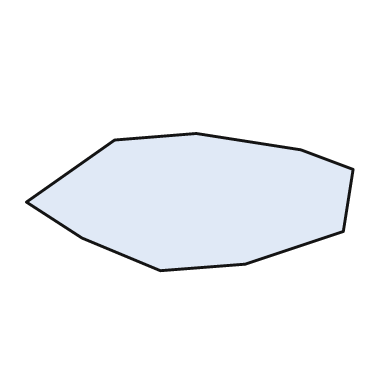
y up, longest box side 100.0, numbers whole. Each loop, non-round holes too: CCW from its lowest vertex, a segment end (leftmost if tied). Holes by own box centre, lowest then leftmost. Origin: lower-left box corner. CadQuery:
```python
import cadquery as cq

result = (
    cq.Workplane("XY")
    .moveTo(41.0, 0.0)
    .lineTo(67.0, 2.0)
    .lineTo(97.0, 12.0)
    .lineTo(100.0, 31.0)
    .lineTo(84.0, 37.0)
    .lineTo(52.0, 42.0)
    .lineTo(27.0, 40.0)
    .lineTo(0.0, 21.0)
    .lineTo(17.0, 10.0)
    .close()
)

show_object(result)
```